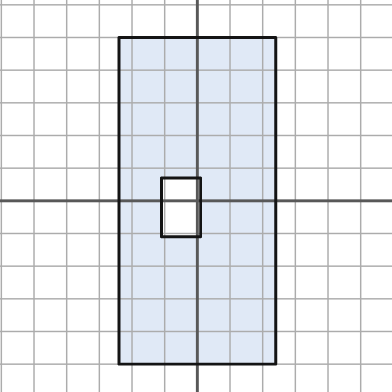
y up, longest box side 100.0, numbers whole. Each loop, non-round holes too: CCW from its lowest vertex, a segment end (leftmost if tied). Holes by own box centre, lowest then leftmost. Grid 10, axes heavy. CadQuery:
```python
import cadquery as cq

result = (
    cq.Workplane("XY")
    .moveTo(-24.0, -50.0)
    .lineTo(24.0, -50.0)
    .lineTo(24.0, 50.0)
    .lineTo(-24.0, 50.0)
    .close()
    .moveTo(-11.0, -11.0)
    .lineTo(1.0, -11.0)
    .lineTo(1.0, 7.0)
    .lineTo(-11.0, 7.0)
    .close()
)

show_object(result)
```